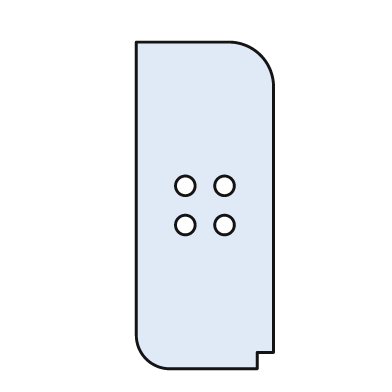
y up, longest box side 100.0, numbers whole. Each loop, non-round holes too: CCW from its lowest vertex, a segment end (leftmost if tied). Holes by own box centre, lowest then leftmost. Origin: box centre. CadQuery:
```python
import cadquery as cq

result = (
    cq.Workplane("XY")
    .moveTo(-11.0, -50.0)
    .lineTo(16.0, -50.0)
    .lineTo(16.0, -45.0)
    .lineTo(21.0, -45.0)
    .lineTo(21.0, 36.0)
    .threePointArc((17.0, 46.0), (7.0, 50.0))
    .lineTo(-21.0, 50.0)
    .lineTo(-21.0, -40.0)
    .threePointArc((-18.0, -47.0), (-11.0, -50.0))
    .close()
    .moveTo(-6.0, -6.0)
    .circle(3.0)
    .moveTo(6.0, -6.0)
    .circle(3.0)
    .moveTo(-6.0, 6.0)
    .circle(3.0)
    .moveTo(6.0, 6.0)
    .circle(3.0)
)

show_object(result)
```